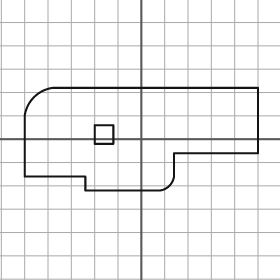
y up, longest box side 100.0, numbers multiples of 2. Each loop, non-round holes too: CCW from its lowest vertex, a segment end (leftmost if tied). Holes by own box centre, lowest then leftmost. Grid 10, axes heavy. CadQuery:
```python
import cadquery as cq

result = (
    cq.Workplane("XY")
    .moveTo(-24.0, -22.0)
    .lineTo(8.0, -22.0)
    .threePointArc((12.0, -20.0), (14.0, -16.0))
    .lineTo(14.0, -6.0)
    .lineTo(50.0, -6.0)
    .lineTo(50.0, 22.0)
    .lineTo(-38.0, 22.0)
    .threePointArc((-46.0, 18.0), (-50.0, 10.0))
    .lineTo(-50.0, -16.0)
    .lineTo(-24.0, -16.0)
    .close()
    .moveTo(-20.0, -2.0)
    .lineTo(-12.0, -2.0)
    .lineTo(-12.0, 6.0)
    .lineTo(-20.0, 6.0)
    .close()
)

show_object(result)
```